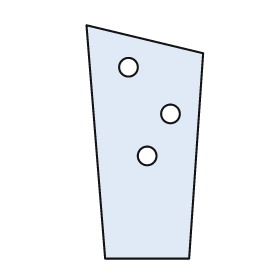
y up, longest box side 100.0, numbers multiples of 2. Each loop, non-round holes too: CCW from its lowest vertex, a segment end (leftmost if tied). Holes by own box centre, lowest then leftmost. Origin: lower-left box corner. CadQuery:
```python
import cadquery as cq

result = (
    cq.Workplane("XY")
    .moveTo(8.0, 0.0)
    .lineTo(44.0, 0.0)
    .lineTo(50.0, 88.0)
    .lineTo(0.0, 100.0)
    .close()
    .moveTo(26.0, 44.0)
    .circle(4.0)
    .moveTo(36.0, 62.0)
    .circle(4.0)
    .moveTo(18.0, 82.0)
    .circle(4.0)
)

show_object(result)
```